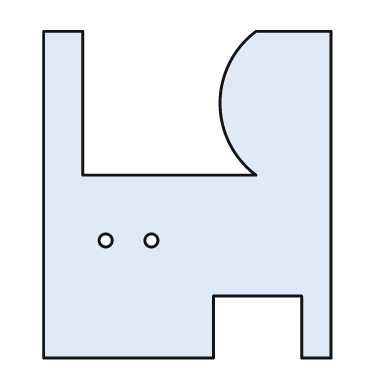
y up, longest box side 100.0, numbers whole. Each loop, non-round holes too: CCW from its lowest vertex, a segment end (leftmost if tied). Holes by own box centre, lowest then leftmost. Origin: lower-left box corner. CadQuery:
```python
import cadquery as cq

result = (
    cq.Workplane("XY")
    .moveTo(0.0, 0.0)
    .lineTo(52.0, 0.0)
    .lineTo(52.0, 19.0)
    .lineTo(79.0, 19.0)
    .lineTo(79.0, 0.0)
    .lineTo(88.0, 0.0)
    .lineTo(88.0, 100.0)
    .lineTo(65.0, 100.0)
    .threePointArc((54.0, 78.0), (65.0, 56.0))
    .lineTo(12.0, 56.0)
    .lineTo(12.0, 100.0)
    .lineTo(0.0, 100.0)
    .close()
    .moveTo(19.0, 36.0)
    .circle(2.0)
    .moveTo(33.0, 36.0)
    .circle(2.0)
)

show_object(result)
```